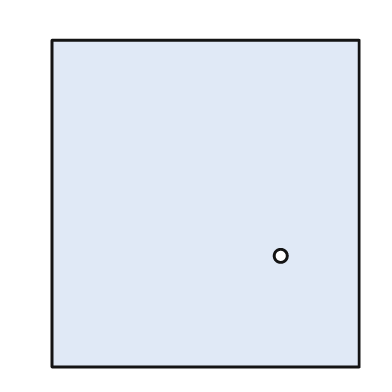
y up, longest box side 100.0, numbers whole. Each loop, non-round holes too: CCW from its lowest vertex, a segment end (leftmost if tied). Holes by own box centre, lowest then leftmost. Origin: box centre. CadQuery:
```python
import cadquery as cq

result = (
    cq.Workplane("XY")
    .moveTo(-47.0, -50.0)
    .lineTo(47.0, -50.0)
    .lineTo(47.0, 50.0)
    .lineTo(-47.0, 50.0)
    .close()
    .moveTo(23.0, -16.0)
    .circle(2.0)
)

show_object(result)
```